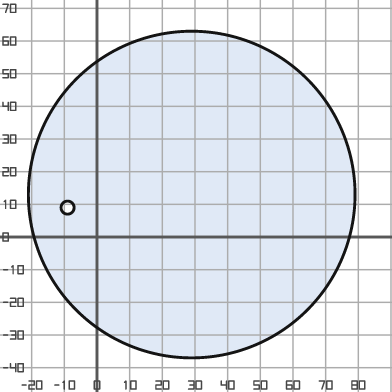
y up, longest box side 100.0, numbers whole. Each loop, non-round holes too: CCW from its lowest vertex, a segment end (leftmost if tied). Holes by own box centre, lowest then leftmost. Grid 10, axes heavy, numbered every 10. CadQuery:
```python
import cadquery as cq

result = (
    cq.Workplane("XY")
    .moveTo(29.0, 13.0)
    .circle(50.0)
    .moveTo(-9.0, 9.0)
    .circle(2.0)
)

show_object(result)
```